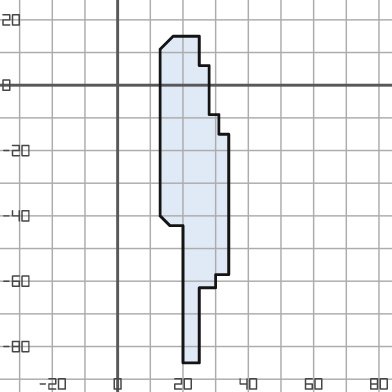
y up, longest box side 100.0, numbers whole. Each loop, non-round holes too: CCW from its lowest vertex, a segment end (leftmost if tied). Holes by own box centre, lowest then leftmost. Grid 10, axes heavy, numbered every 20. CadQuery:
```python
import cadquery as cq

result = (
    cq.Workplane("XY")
    .moveTo(20.0, -85.0)
    .lineTo(25.0, -85.0)
    .lineTo(25.0, -62.0)
    .lineTo(30.0, -62.0)
    .lineTo(30.0, -58.0)
    .lineTo(34.0, -58.0)
    .lineTo(34.0, -15.0)
    .lineTo(31.0, -15.0)
    .lineTo(31.0, -9.0)
    .lineTo(28.0, -9.0)
    .lineTo(28.0, 6.0)
    .lineTo(25.0, 6.0)
    .lineTo(25.0, 15.0)
    .lineTo(17.0, 15.0)
    .lineTo(13.0, 11.0)
    .lineTo(13.0, -40.0)
    .lineTo(16.0, -43.0)
    .lineTo(20.0, -43.0)
    .close()
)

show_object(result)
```